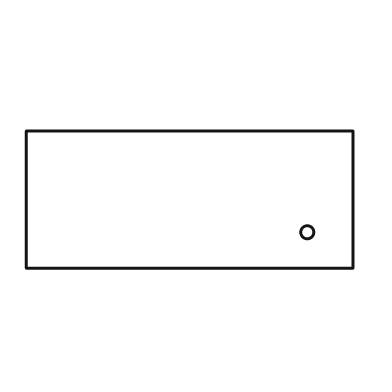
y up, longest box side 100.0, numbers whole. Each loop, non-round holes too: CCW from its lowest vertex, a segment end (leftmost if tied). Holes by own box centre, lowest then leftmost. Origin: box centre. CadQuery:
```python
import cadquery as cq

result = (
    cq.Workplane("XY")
    .moveTo(-50.0, -21.0)
    .lineTo(50.0, -21.0)
    .lineTo(50.0, 21.0)
    .lineTo(-50.0, 21.0)
    .close()
    .moveTo(36.0, -10.0)
    .circle(2.0)
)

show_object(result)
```